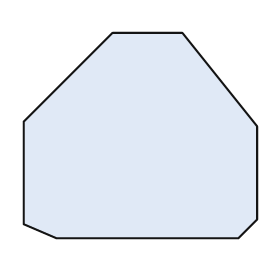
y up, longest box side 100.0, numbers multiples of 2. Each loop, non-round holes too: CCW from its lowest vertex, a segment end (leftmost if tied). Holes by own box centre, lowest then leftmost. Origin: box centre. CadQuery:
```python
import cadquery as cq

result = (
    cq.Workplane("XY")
    .moveTo(-36.0, -44.0)
    .lineTo(42.0, -44.0)
    .lineTo(50.0, -36.0)
    .lineTo(50.0, 4.0)
    .lineTo(18.0, 44.0)
    .lineTo(-12.0, 44.0)
    .lineTo(-50.0, 6.0)
    .lineTo(-50.0, -38.0)
    .close()
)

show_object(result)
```